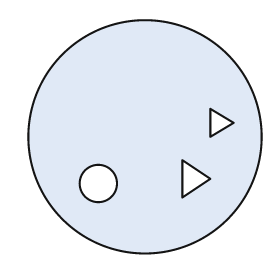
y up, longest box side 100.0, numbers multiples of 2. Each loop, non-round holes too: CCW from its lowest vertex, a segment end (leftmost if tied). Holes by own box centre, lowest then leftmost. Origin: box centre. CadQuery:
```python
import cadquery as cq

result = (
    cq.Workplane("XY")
    .moveTo(0.0, 0.0)
    .circle(50.0)
    .moveTo(-20.0, -20.0)
    .circle(8.0)
    .moveTo(16.0, -26.0)
    .lineTo(28.0, -18.0)
    .lineTo(16.0, -10.0)
    .close()
    .moveTo(28.0, 0.0)
    .lineTo(38.0, 6.0)
    .lineTo(28.0, 12.0)
    .close()
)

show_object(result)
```